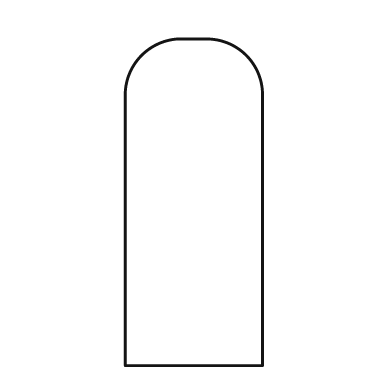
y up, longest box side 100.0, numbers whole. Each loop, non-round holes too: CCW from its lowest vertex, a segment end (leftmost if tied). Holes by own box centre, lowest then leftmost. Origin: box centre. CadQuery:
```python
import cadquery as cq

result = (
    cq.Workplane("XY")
    .moveTo(-21.0, -50.0)
    .lineTo(21.0, -50.0)
    .lineTo(21.0, 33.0)
    .threePointArc((16.0, 45.0), (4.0, 50.0))
    .lineTo(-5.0, 50.0)
    .threePointArc((-16.0, 45.0), (-21.0, 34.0))
    .close()
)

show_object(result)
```